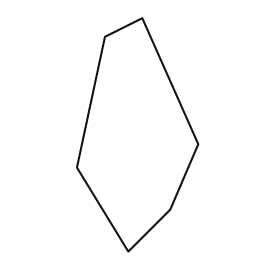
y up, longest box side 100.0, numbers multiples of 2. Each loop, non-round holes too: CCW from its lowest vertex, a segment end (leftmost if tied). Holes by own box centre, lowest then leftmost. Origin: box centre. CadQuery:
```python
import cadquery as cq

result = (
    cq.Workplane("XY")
    .moveTo(-4.0, -50.0)
    .lineTo(14.0, -32.0)
    .lineTo(26.0, -4.0)
    .lineTo(2.0, 50.0)
    .lineTo(-14.0, 42.0)
    .lineTo(-26.0, -14.0)
    .close()
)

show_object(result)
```